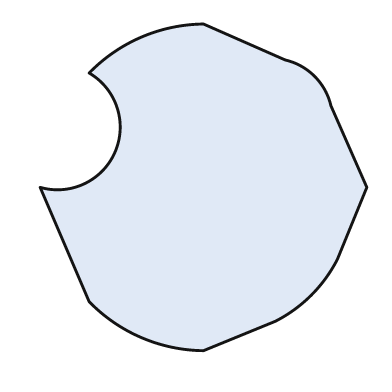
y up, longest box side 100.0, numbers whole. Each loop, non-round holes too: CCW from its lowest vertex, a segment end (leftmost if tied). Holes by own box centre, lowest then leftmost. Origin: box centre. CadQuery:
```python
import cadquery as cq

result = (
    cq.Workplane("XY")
    .moveTo(0.0, -50.0)
    .lineTo(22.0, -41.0)
    .threePointArc((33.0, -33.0), (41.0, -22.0))
    .lineTo(50.0, 0.0)
    .lineTo(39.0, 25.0)
    .threePointArc((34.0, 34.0), (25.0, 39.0))
    .lineTo(0.0, 50.0)
    .threePointArc((-19.0, 46.0), (-35.0, 35.0))
    .threePointArc((-27.0, 11.0), (-50.0, 0.0))
    .lineTo(-35.0, -35.0)
    .threePointArc((-19.0, -46.0), (0.0, -50.0))
    .close()
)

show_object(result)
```